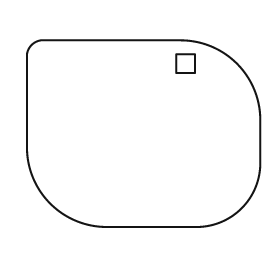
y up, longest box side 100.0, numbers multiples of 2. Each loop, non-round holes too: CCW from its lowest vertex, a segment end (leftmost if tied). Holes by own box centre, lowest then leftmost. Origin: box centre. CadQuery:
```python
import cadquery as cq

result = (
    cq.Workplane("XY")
    .moveTo(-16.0, -40.0)
    .lineTo(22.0, -40.0)
    .threePointArc((42.0, -32.0), (50.0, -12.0))
    .lineTo(50.0, 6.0)
    .threePointArc((40.0, 30.0), (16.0, 40.0))
    .lineTo(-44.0, 40.0)
    .threePointArc((-48.0, 38.0), (-50.0, 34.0))
    .lineTo(-50.0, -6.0)
    .threePointArc((-40.0, -30.0), (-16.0, -40.0))
    .close()
    .moveTo(14.0, 26.0)
    .lineTo(22.0, 26.0)
    .lineTo(22.0, 34.0)
    .lineTo(14.0, 34.0)
    .close()
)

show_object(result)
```